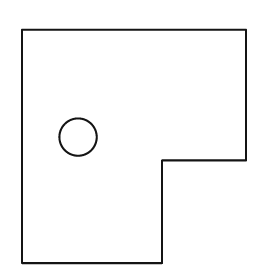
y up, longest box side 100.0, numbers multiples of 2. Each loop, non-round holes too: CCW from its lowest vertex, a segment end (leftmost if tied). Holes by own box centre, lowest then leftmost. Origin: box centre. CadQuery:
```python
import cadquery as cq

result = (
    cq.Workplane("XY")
    .moveTo(-48.0, -50.0)
    .lineTo(12.0, -50.0)
    .lineTo(12.0, -6.0)
    .lineTo(48.0, -6.0)
    .lineTo(48.0, 50.0)
    .lineTo(-48.0, 50.0)
    .close()
    .moveTo(-24.0, 4.0)
    .circle(8.0)
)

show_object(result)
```